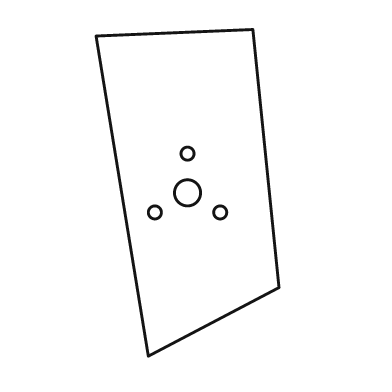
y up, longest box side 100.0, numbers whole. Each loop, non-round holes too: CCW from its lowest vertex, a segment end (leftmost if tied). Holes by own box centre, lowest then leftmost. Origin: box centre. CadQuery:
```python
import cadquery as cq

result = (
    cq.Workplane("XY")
    .moveTo(-12.0, -50.0)
    .lineTo(28.0, -29.0)
    .lineTo(20.0, 50.0)
    .lineTo(-28.0, 48.0)
    .close()
    .moveTo(-10.0, -6.0)
    .circle(2.0)
    .moveTo(10.0, -6.0)
    .circle(2.0)
    .moveTo(0.0, 0.0)
    .circle(4.0)
    .moveTo(0.0, 12.0)
    .circle(2.0)
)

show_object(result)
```